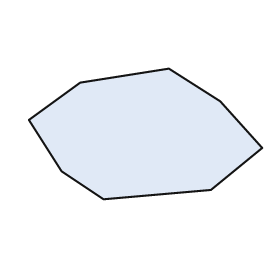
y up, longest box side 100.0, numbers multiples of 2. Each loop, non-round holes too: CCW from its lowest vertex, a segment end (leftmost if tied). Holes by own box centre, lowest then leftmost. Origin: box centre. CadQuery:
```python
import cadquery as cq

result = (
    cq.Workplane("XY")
    .moveTo(-18.0, -28.0)
    .lineTo(28.0, -24.0)
    .lineTo(50.0, -6.0)
    .lineTo(32.0, 14.0)
    .lineTo(10.0, 28.0)
    .lineTo(-28.0, 22.0)
    .lineTo(-50.0, 6.0)
    .lineTo(-36.0, -16.0)
    .close()
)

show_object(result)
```